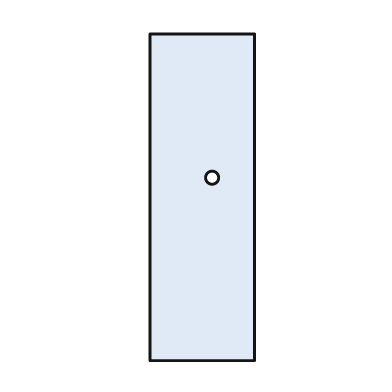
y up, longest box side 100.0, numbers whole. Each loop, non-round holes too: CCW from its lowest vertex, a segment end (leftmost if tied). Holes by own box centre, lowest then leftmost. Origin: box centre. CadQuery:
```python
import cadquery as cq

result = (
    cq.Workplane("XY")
    .moveTo(-16.0, -50.0)
    .lineTo(16.0, -50.0)
    .lineTo(16.0, 50.0)
    .lineTo(-16.0, 50.0)
    .close()
    .moveTo(3.0, 6.0)
    .circle(2.0)
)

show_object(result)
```